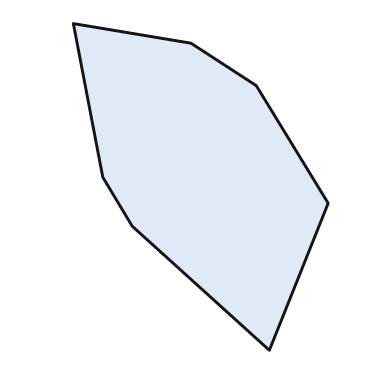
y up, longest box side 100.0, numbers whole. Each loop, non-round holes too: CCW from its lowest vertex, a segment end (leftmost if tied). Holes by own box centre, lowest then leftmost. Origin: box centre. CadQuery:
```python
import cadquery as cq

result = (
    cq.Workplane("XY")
    .moveTo(21.0, -50.0)
    .lineTo(39.0, -5.0)
    .lineTo(17.0, 31.0)
    .lineTo(-3.0, 44.0)
    .lineTo(-39.0, 50.0)
    .lineTo(-30.0, 3.0)
    .lineTo(-21.0, -12.0)
    .close()
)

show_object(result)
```